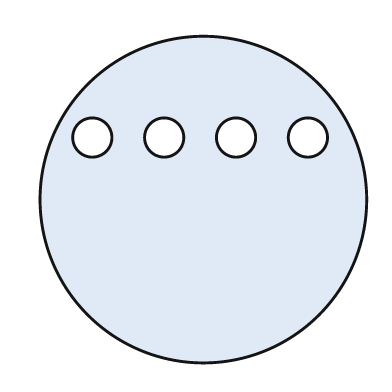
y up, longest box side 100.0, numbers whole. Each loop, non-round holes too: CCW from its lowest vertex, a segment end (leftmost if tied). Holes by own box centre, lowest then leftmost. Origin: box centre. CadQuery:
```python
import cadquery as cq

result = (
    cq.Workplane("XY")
    .moveTo(0.0, 0.0)
    .circle(50.0)
    .moveTo(-34.0, 19.0)
    .circle(6.0)
    .moveTo(-12.0, 19.0)
    .circle(6.0)
    .moveTo(10.0, 19.0)
    .circle(6.0)
    .moveTo(32.0, 19.0)
    .circle(6.0)
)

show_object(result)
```